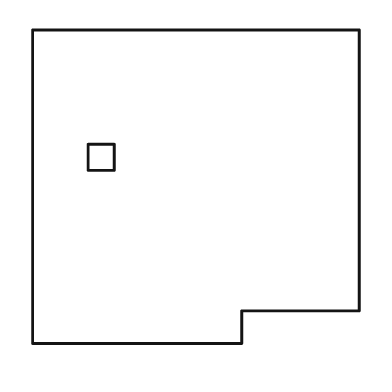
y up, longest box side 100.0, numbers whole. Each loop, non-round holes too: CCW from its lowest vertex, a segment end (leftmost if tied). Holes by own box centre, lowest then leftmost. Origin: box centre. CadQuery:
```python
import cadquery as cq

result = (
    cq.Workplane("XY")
    .moveTo(-50.0, -48.0)
    .lineTo(14.0, -48.0)
    .lineTo(14.0, -38.0)
    .lineTo(50.0, -38.0)
    .lineTo(50.0, 48.0)
    .lineTo(-50.0, 48.0)
    .close()
    .moveTo(-33.0, 5.0)
    .lineTo(-25.0, 5.0)
    .lineTo(-25.0, 13.0)
    .lineTo(-33.0, 13.0)
    .close()
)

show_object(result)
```